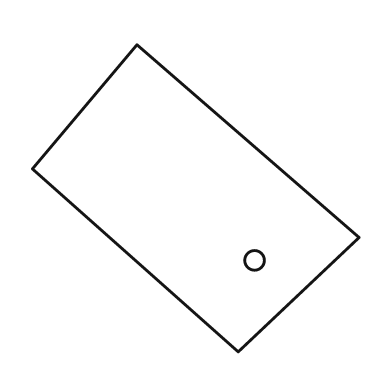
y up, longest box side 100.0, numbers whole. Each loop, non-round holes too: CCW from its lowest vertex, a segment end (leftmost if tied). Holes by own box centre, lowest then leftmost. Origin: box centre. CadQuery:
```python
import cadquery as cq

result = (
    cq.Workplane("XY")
    .moveTo(13.0, -47.0)
    .lineTo(50.0, -12.0)
    .lineTo(-18.0, 47.0)
    .lineTo(-50.0, 9.0)
    .close()
    .moveTo(18.0, -19.0)
    .circle(3.0)
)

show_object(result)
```